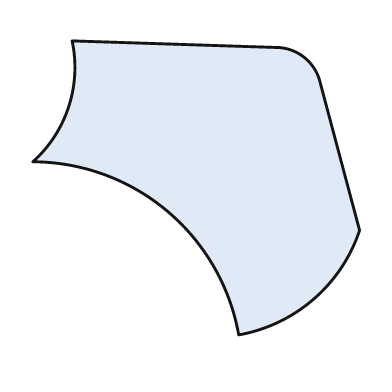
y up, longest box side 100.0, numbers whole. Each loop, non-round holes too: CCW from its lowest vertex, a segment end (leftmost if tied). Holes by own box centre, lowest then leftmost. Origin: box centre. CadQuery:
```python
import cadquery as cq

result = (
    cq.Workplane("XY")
    .moveTo(13.0, -45.0)
    .threePointArc((36.0, -34.0), (50.0, -13.0))
    .lineTo(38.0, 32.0)
    .threePointArc((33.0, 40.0), (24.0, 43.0))
    .lineTo(-38.0, 45.0)
    .threePointArc((-39.0, 25.0), (-50.0, 8.0))
    .threePointArc((-9.0, -7.0), (13.0, -45.0))
    .close()
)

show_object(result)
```